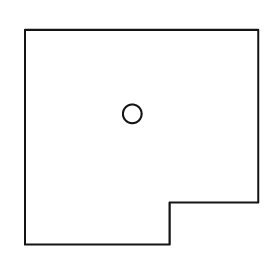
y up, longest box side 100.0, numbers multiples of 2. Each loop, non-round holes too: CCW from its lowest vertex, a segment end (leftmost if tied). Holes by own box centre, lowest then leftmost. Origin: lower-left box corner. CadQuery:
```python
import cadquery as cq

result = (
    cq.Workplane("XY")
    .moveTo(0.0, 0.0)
    .lineTo(62.0, 0.0)
    .lineTo(62.0, 18.0)
    .lineTo(100.0, 18.0)
    .lineTo(100.0, 92.0)
    .lineTo(0.0, 92.0)
    .close()
    .moveTo(46.0, 56.0)
    .circle(4.0)
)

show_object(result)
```